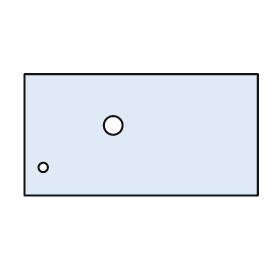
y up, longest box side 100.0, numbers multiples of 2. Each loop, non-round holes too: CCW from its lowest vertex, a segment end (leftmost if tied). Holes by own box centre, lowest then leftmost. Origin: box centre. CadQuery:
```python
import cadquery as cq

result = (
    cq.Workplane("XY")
    .moveTo(-50.0, -26.0)
    .lineTo(50.0, -26.0)
    .lineTo(50.0, 26.0)
    .lineTo(-50.0, 26.0)
    .close()
    .moveTo(-42.0, -14.0)
    .circle(2.0)
    .moveTo(-12.0, 4.0)
    .circle(4.0)
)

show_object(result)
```